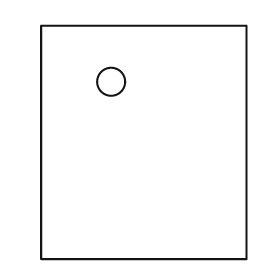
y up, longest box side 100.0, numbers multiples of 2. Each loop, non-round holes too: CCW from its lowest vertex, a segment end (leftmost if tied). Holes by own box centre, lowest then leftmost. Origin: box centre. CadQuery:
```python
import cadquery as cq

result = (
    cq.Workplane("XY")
    .moveTo(-44.0, -50.0)
    .lineTo(44.0, -50.0)
    .lineTo(44.0, 50.0)
    .lineTo(-44.0, 50.0)
    .close()
    .moveTo(-14.0, 26.0)
    .circle(6.0)
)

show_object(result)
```